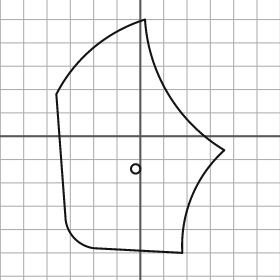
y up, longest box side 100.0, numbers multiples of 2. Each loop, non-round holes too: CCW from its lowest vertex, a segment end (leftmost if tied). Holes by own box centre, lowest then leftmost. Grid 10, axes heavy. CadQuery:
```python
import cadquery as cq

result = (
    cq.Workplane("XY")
    .moveTo(18.0, -50.0)
    .threePointArc((22.0, -26.0), (36.0, -6.0))
    .threePointArc((12.0, 18.0), (2.0, 50.0))
    .threePointArc((-20.0, 38.0), (-36.0, 18.0))
    .lineTo(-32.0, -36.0)
    .threePointArc((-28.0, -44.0), (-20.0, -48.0))
    .close()
    .moveTo(-2.0, -14.0)
    .circle(2.0)
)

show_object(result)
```